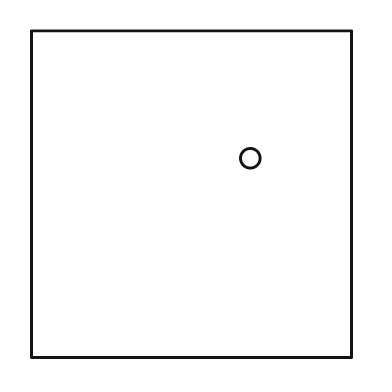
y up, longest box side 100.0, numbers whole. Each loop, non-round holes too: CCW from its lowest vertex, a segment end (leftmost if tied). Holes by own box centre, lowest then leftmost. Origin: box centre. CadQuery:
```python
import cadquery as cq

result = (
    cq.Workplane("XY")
    .moveTo(-49.0, -50.0)
    .lineTo(49.0, -50.0)
    .lineTo(49.0, 50.0)
    .lineTo(-49.0, 50.0)
    .close()
    .moveTo(18.0, 11.0)
    .circle(3.0)
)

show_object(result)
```